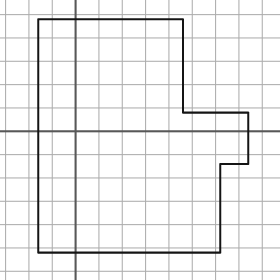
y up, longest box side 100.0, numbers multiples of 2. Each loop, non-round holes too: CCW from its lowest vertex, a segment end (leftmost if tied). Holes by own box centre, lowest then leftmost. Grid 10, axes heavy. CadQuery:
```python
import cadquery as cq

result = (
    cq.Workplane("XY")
    .moveTo(-16.0, -52.0)
    .lineTo(62.0, -52.0)
    .lineTo(62.0, -14.0)
    .lineTo(74.0, -14.0)
    .lineTo(74.0, 8.0)
    .lineTo(46.0, 8.0)
    .lineTo(46.0, 48.0)
    .lineTo(-16.0, 48.0)
    .close()
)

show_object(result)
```